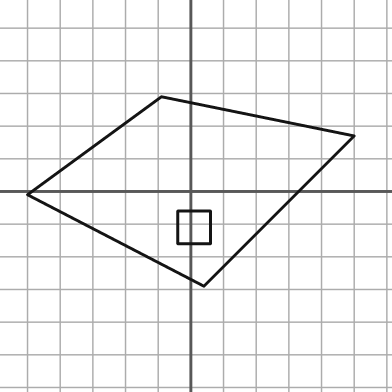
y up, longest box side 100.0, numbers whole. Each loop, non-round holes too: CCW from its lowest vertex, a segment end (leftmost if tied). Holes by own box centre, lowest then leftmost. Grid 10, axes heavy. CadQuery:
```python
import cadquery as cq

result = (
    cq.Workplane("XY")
    .moveTo(4.0, -29.0)
    .lineTo(50.0, 17.0)
    .lineTo(-9.0, 29.0)
    .lineTo(-50.0, -1.0)
    .close()
    .moveTo(-4.0, -16.0)
    .lineTo(6.0, -16.0)
    .lineTo(6.0, -6.0)
    .lineTo(-4.0, -6.0)
    .close()
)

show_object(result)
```